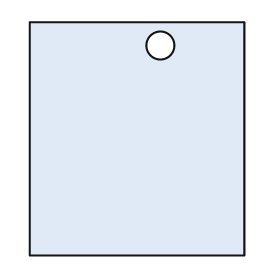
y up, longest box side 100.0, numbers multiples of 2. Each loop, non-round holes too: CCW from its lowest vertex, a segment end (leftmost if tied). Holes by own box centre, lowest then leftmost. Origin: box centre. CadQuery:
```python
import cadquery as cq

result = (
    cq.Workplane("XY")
    .moveTo(-46.0, -50.0)
    .lineTo(46.0, -50.0)
    .lineTo(46.0, 50.0)
    .lineTo(-46.0, 50.0)
    .close()
    .moveTo(10.0, 40.0)
    .circle(6.0)
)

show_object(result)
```